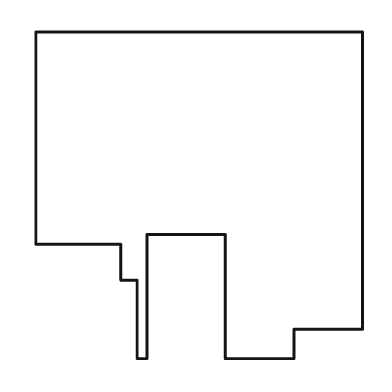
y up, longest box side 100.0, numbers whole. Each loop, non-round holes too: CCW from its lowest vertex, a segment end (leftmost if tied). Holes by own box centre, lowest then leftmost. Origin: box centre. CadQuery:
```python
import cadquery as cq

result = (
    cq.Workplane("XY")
    .moveTo(-19.0, -50.0)
    .lineTo(-16.0, -50.0)
    .lineTo(-16.0, -12.0)
    .lineTo(8.0, -12.0)
    .lineTo(8.0, -50.0)
    .lineTo(29.0, -50.0)
    .lineTo(29.0, -41.0)
    .lineTo(50.0, -41.0)
    .lineTo(50.0, 50.0)
    .lineTo(-50.0, 50.0)
    .lineTo(-50.0, -15.0)
    .lineTo(-24.0, -15.0)
    .lineTo(-24.0, -26.0)
    .lineTo(-19.0, -26.0)
    .close()
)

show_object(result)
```